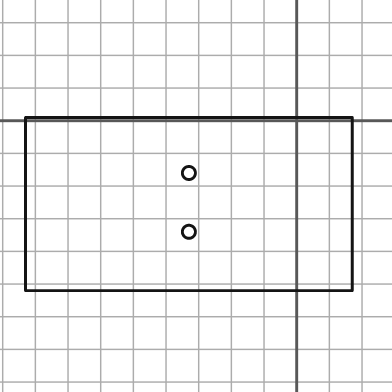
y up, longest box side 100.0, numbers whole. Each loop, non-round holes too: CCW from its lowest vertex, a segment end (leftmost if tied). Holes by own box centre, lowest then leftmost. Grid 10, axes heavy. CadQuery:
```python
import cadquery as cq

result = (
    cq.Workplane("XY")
    .moveTo(-83.0, -52.0)
    .lineTo(17.0, -52.0)
    .lineTo(17.0, 1.0)
    .lineTo(-83.0, 1.0)
    .close()
    .moveTo(-33.0, -34.0)
    .circle(2.0)
    .moveTo(-33.0, -16.0)
    .circle(2.0)
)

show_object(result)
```